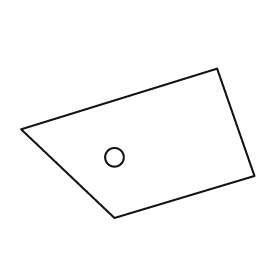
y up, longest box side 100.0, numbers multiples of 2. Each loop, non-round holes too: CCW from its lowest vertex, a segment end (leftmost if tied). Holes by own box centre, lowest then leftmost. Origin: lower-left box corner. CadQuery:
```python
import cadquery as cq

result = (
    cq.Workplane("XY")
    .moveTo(40.0, 0.0)
    .lineTo(100.0, 18.0)
    .lineTo(84.0, 64.0)
    .lineTo(0.0, 38.0)
    .close()
    .moveTo(40.0, 26.0)
    .circle(4.0)
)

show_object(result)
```